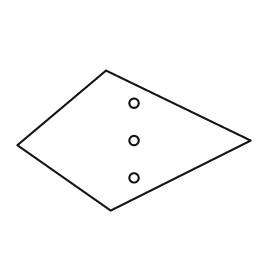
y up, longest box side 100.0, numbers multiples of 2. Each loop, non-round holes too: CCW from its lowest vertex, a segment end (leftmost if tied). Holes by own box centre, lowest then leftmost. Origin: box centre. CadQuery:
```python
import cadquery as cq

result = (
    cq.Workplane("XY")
    .moveTo(-10.0, -30.0)
    .lineTo(50.0, 0.0)
    .lineTo(-12.0, 30.0)
    .lineTo(-50.0, -2.0)
    .close()
    .moveTo(0.0, -16.0)
    .circle(2.0)
    .moveTo(0.0, 0.0)
    .circle(2.0)
    .moveTo(0.0, 16.0)
    .circle(2.0)
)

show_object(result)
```